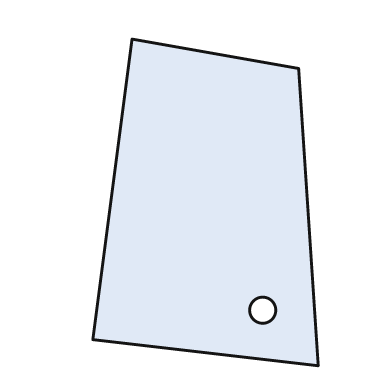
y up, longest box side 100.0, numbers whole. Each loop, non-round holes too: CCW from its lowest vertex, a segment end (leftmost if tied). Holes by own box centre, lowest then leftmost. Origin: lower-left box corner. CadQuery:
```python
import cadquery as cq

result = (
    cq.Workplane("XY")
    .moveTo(69.0, 0.0)
    .lineTo(63.0, 91.0)
    .lineTo(12.0, 100.0)
    .lineTo(0.0, 8.0)
    .close()
    .moveTo(52.0, 17.0)
    .circle(4.0)
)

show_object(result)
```